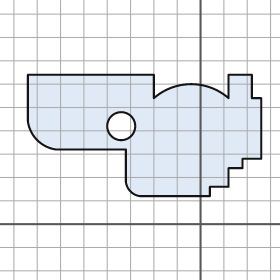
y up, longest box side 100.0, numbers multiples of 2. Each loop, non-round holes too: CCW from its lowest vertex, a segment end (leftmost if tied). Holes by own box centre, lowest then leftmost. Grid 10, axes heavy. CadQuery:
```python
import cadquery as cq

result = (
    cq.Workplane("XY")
    .moveTo(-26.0, 12.0)
    .lineTo(4.0, 12.0)
    .lineTo(4.0, 16.0)
    .lineTo(12.0, 16.0)
    .lineTo(12.0, 24.0)
    .lineTo(18.0, 24.0)
    .lineTo(18.0, 28.0)
    .lineTo(26.0, 28.0)
    .lineTo(26.0, 54.0)
    .lineTo(22.0, 54.0)
    .lineTo(22.0, 64.0)
    .lineTo(12.0, 64.0)
    .lineTo(12.0, 54.0)
    .threePointArc((-4.0, 60.0), (-20.0, 54.0))
    .lineTo(-20.0, 64.0)
    .lineTo(-74.0, 64.0)
    .lineTo(-74.0, 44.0)
    .threePointArc((-70.0, 36.0), (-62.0, 32.0))
    .lineTo(-32.0, 32.0)
    .lineTo(-32.0, 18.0)
    .threePointArc((-30.0, 14.0), (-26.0, 12.0))
    .close()
    .moveTo(-34.0, 42.0)
    .circle(6.0)
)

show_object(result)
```